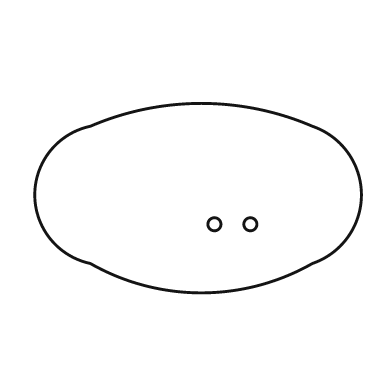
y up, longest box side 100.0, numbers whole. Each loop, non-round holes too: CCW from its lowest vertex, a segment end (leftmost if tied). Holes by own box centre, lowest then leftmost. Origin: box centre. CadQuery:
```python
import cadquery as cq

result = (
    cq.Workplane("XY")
    .moveTo(-33.0, -20.0)
    .threePointArc((1.0, -29.0), (35.0, -20.0))
    .threePointArc((50.0, 1.0), (35.0, 22.0))
    .threePointArc((1.0, 29.0), (-33.0, 22.0))
    .threePointArc((-50.0, 1.0), (-33.0, -20.0))
    .close()
    .moveTo(5.0, -8.0)
    .circle(2.0)
    .moveTo(16.0, -8.0)
    .circle(2.0)
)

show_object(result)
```